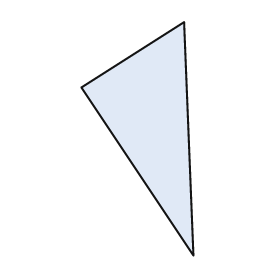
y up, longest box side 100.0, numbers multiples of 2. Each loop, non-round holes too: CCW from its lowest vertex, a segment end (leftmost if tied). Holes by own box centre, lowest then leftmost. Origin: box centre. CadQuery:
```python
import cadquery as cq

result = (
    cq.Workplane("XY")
    .moveTo(24.0, -50.0)
    .lineTo(20.0, 50.0)
    .lineTo(-24.0, 22.0)
    .close()
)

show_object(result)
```